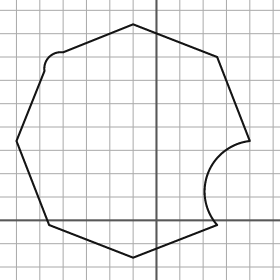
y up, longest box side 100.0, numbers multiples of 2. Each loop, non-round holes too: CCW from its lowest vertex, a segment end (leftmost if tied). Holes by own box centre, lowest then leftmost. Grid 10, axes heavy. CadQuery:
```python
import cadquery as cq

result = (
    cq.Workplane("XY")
    .moveTo(-10.0, -16.0)
    .lineTo(26.0, -2.0)
    .threePointArc((22.0, 20.0), (40.0, 34.0))
    .lineTo(26.0, 70.0)
    .lineTo(-10.0, 84.0)
    .lineTo(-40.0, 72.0)
    .threePointArc((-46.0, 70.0), (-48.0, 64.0))
    .lineTo(-60.0, 34.0)
    .lineTo(-46.0, -2.0)
    .close()
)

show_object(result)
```